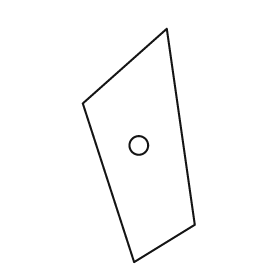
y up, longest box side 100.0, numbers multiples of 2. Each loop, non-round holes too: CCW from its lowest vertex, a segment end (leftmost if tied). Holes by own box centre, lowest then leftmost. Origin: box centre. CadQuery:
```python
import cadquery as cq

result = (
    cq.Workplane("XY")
    .moveTo(-2.0, -50.0)
    .lineTo(24.0, -34.0)
    .lineTo(12.0, 50.0)
    .lineTo(-24.0, 18.0)
    .close()
    .moveTo(0.0, 0.0)
    .circle(4.0)
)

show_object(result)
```